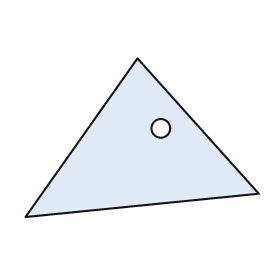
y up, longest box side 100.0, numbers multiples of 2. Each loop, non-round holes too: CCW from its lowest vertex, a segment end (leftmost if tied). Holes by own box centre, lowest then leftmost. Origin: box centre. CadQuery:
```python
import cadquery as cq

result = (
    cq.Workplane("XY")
    .moveTo(-50.0, -34.0)
    .lineTo(50.0, -24.0)
    .lineTo(-2.0, 34.0)
    .close()
    .moveTo(8.0, 4.0)
    .circle(4.0)
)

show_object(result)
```